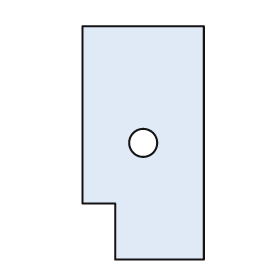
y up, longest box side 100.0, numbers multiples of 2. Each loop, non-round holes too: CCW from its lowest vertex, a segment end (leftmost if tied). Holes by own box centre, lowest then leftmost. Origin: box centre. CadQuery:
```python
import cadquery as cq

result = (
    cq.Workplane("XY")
    .moveTo(-12.0, -50.0)
    .lineTo(26.0, -50.0)
    .lineTo(26.0, 50.0)
    .lineTo(-26.0, 50.0)
    .lineTo(-26.0, -26.0)
    .lineTo(-12.0, -26.0)
    .close()
    .moveTo(0.0, 0.0)
    .circle(6.0)
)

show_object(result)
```